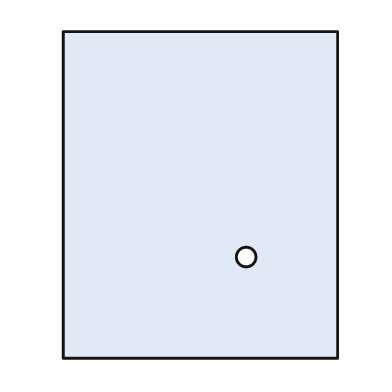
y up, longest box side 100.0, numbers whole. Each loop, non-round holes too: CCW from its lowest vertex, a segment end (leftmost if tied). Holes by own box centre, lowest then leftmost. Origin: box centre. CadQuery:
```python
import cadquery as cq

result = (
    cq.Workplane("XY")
    .moveTo(-42.0, -50.0)
    .lineTo(42.0, -50.0)
    .lineTo(42.0, 50.0)
    .lineTo(-42.0, 50.0)
    .close()
    .moveTo(14.0, -19.0)
    .circle(3.0)
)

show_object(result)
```